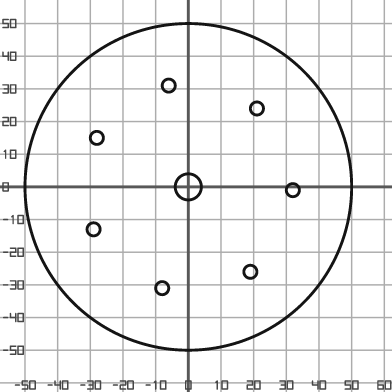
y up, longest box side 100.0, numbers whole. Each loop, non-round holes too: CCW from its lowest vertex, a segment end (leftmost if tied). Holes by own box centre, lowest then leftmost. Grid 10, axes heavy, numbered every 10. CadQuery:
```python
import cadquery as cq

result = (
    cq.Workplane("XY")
    .moveTo(0.0, 0.0)
    .circle(50.0)
    .moveTo(-8.0, -31.0)
    .circle(2.0)
    .moveTo(19.0, -26.0)
    .circle(2.0)
    .moveTo(-29.0, -13.0)
    .circle(2.0)
    .moveTo(32.0, -1.0)
    .circle(2.0)
    .moveTo(0.0, 0.0)
    .circle(4.0)
    .moveTo(-28.0, 15.0)
    .circle(2.0)
    .moveTo(21.0, 24.0)
    .circle(2.0)
    .moveTo(-6.0, 31.0)
    .circle(2.0)
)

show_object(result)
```